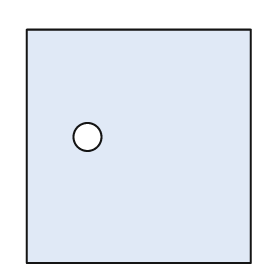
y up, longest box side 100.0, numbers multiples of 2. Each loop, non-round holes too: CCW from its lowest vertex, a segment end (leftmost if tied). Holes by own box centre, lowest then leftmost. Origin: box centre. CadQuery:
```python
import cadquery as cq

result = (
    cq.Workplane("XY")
    .moveTo(-48.0, -50.0)
    .lineTo(48.0, -50.0)
    .lineTo(48.0, 50.0)
    .lineTo(-48.0, 50.0)
    .close()
    .moveTo(-22.0, 4.0)
    .circle(6.0)
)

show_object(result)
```